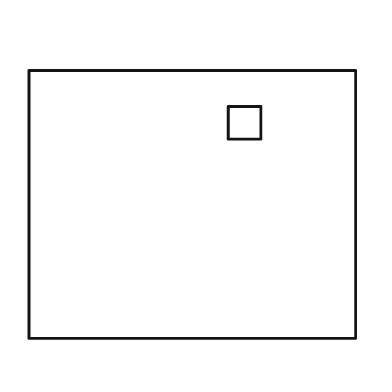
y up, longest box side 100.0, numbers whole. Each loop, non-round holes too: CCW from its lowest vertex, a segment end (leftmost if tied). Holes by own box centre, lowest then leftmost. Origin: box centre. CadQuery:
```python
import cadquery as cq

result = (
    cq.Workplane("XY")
    .moveTo(-50.0, -41.0)
    .lineTo(50.0, -41.0)
    .lineTo(50.0, 41.0)
    .lineTo(-50.0, 41.0)
    .close()
    .moveTo(11.0, 20.0)
    .lineTo(21.0, 20.0)
    .lineTo(21.0, 30.0)
    .lineTo(11.0, 30.0)
    .close()
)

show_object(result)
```